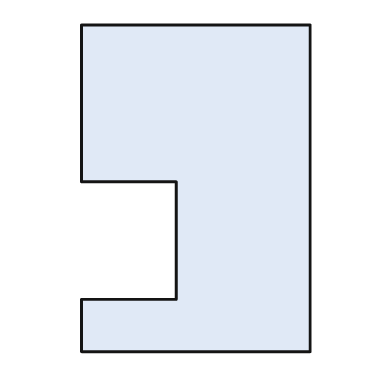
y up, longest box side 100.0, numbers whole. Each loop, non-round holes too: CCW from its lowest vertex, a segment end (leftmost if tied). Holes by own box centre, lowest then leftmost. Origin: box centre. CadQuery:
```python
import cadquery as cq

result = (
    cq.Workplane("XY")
    .moveTo(-35.0, -50.0)
    .lineTo(35.0, -50.0)
    .lineTo(35.0, 50.0)
    .lineTo(-35.0, 50.0)
    .lineTo(-35.0, 2.0)
    .lineTo(-6.0, 2.0)
    .lineTo(-6.0, -34.0)
    .lineTo(-35.0, -34.0)
    .close()
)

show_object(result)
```